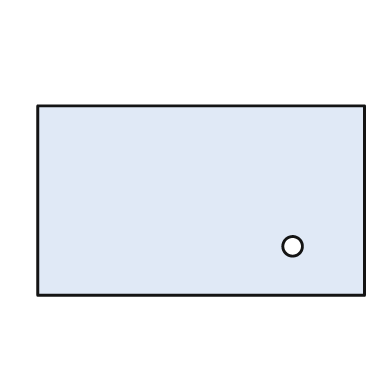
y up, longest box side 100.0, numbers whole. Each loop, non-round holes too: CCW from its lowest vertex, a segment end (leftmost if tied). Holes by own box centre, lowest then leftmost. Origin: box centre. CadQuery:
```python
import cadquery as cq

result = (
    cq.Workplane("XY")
    .moveTo(-50.0, -29.0)
    .lineTo(50.0, -29.0)
    .lineTo(50.0, 29.0)
    .lineTo(-50.0, 29.0)
    .close()
    .moveTo(28.0, -14.0)
    .circle(3.0)
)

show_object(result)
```